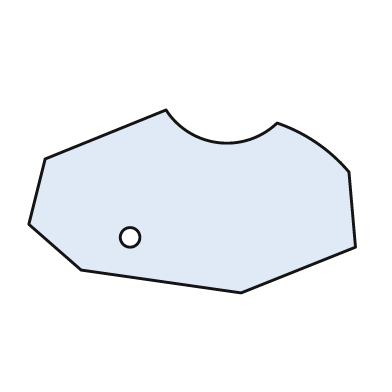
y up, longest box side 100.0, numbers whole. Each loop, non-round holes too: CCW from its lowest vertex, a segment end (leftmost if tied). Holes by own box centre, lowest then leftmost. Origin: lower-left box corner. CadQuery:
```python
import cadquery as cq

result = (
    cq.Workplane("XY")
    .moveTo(65.0, 0.0)
    .lineTo(100.0, 14.0)
    .lineTo(98.0, 37.0)
    .threePointArc((88.0, 46.0), (76.0, 52.0))
    .threePointArc((58.0, 46.0), (42.0, 56.0))
    .lineTo(5.0, 41.0)
    .lineTo(0.0, 21.0)
    .lineTo(16.0, 7.0)
    .close()
    .moveTo(31.0, 17.0)
    .circle(3.0)
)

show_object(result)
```